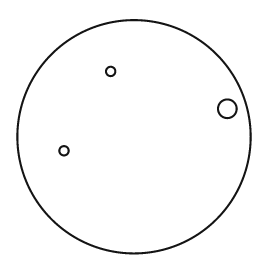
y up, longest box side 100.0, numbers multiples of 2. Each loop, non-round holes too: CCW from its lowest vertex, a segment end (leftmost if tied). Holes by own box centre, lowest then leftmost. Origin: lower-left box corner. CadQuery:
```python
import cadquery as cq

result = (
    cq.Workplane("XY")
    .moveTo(50.0, 50.0)
    .circle(50.0)
    .moveTo(20.0, 44.0)
    .circle(2.0)
    .moveTo(90.0, 62.0)
    .circle(4.0)
    .moveTo(40.0, 78.0)
    .circle(2.0)
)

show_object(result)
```